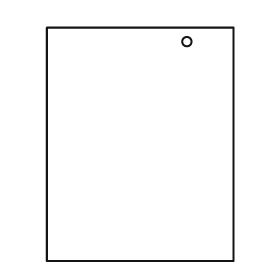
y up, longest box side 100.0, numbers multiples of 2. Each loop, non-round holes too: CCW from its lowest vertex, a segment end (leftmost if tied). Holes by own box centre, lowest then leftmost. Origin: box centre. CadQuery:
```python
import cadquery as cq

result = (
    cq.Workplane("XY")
    .moveTo(-40.0, -50.0)
    .lineTo(40.0, -50.0)
    .lineTo(40.0, 50.0)
    .lineTo(-40.0, 50.0)
    .close()
    .moveTo(20.0, 44.0)
    .circle(2.0)
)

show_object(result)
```